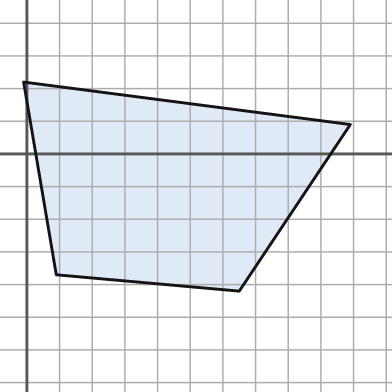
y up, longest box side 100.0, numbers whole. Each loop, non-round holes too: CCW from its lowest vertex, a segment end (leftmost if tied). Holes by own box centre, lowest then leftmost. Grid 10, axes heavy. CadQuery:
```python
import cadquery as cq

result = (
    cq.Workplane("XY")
    .moveTo(65.0, -42.0)
    .lineTo(99.0, 9.0)
    .lineTo(-1.0, 22.0)
    .lineTo(9.0, -37.0)
    .close()
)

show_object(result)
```